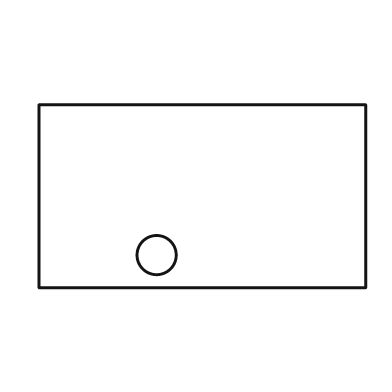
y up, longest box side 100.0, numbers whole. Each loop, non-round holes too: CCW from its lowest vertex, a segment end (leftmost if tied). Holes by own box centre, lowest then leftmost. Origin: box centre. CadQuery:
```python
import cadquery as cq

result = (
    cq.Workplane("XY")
    .moveTo(-50.0, -28.0)
    .lineTo(50.0, -28.0)
    .lineTo(50.0, 28.0)
    .lineTo(-50.0, 28.0)
    .close()
    .moveTo(-14.0, -18.0)
    .circle(6.0)
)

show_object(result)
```